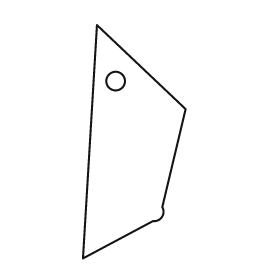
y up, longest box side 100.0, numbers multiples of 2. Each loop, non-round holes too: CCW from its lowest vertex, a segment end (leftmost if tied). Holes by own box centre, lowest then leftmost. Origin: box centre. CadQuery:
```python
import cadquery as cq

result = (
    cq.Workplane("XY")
    .moveTo(-22.0, -50.0)
    .lineTo(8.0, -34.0)
    .threePointArc((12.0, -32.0), (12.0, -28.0))
    .lineTo(22.0, 14.0)
    .lineTo(-16.0, 50.0)
    .close()
    .moveTo(-8.0, 26.0)
    .circle(4.0)
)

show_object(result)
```